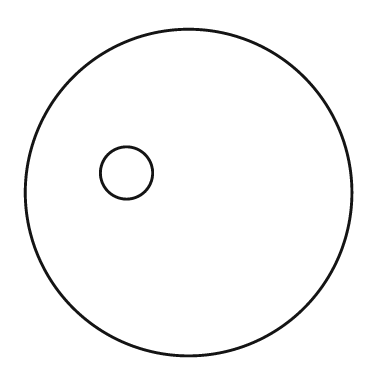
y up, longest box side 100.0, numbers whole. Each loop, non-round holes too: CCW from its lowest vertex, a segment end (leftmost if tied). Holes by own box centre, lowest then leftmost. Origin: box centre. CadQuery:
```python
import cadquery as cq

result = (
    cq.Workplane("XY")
    .moveTo(0.0, 0.0)
    .circle(50.0)
    .moveTo(-19.0, 6.0)
    .circle(8.0)
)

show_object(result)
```